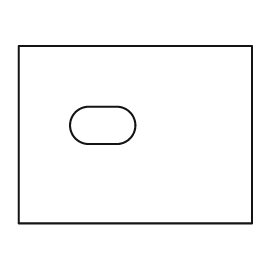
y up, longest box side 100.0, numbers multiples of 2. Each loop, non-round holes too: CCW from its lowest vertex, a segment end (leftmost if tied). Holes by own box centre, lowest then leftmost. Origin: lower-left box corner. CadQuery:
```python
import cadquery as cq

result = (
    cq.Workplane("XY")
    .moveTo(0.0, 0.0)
    .lineTo(100.0, 0.0)
    .lineTo(100.0, 76.0)
    .lineTo(0.0, 76.0)
    .close()
    .moveTo(30.0, 34.0)
    .lineTo(42.0, 34.0)
    .threePointArc((50.0, 42.0), (42.0, 50.0))
    .lineTo(30.0, 50.0)
    .threePointArc((22.0, 42.0), (30.0, 34.0))
    .close()
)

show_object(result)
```